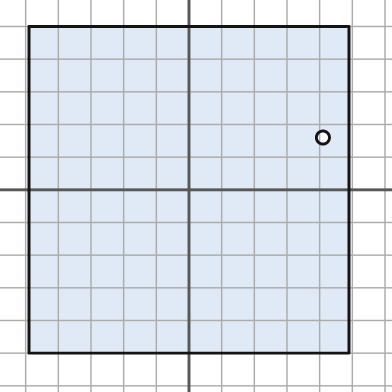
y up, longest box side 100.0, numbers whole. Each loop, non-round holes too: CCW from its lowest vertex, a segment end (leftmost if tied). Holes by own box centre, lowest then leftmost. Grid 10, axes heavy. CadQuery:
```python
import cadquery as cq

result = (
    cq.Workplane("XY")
    .moveTo(-49.0, -50.0)
    .lineTo(49.0, -50.0)
    .lineTo(49.0, 50.0)
    .lineTo(-49.0, 50.0)
    .close()
    .moveTo(41.0, 16.0)
    .circle(2.0)
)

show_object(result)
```